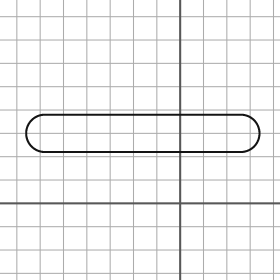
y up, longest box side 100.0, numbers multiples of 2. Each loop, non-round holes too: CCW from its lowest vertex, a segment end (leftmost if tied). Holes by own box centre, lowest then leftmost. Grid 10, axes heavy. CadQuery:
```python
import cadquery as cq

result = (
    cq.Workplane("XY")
    .moveTo(-58.0, 22.0)
    .lineTo(26.0, 22.0)
    .threePointArc((34.0, 30.0), (26.0, 38.0))
    .lineTo(-58.0, 38.0)
    .threePointArc((-66.0, 30.0), (-58.0, 22.0))
    .close()
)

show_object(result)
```